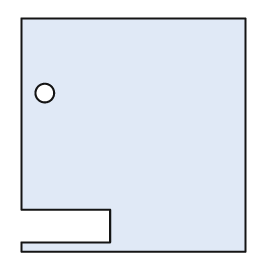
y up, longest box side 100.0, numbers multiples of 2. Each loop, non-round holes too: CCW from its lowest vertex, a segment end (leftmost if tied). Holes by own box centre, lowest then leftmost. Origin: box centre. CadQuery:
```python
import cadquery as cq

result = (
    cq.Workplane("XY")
    .moveTo(-48.0, -50.0)
    .lineTo(48.0, -50.0)
    .lineTo(48.0, 50.0)
    .lineTo(-48.0, 50.0)
    .lineTo(-48.0, -32.0)
    .lineTo(-10.0, -32.0)
    .lineTo(-10.0, -46.0)
    .lineTo(-48.0, -46.0)
    .close()
    .moveTo(-38.0, 18.0)
    .circle(4.0)
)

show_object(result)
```